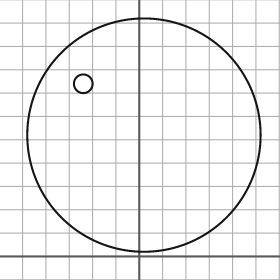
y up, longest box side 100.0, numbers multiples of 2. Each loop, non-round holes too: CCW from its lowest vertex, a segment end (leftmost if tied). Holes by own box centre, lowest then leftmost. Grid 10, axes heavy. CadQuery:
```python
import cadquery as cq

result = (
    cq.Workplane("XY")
    .moveTo(2.0, 52.0)
    .circle(50.0)
    .moveTo(-24.0, 74.0)
    .circle(4.0)
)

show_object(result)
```